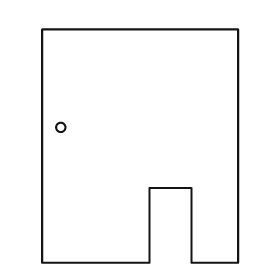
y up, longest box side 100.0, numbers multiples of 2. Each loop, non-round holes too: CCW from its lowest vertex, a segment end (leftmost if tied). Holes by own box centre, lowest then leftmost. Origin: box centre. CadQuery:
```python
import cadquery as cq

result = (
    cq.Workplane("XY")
    .moveTo(-42.0, -50.0)
    .lineTo(4.0, -50.0)
    .lineTo(4.0, -18.0)
    .lineTo(22.0, -18.0)
    .lineTo(22.0, -50.0)
    .lineTo(42.0, -50.0)
    .lineTo(42.0, 50.0)
    .lineTo(-42.0, 50.0)
    .close()
    .moveTo(-34.0, 8.0)
    .circle(2.0)
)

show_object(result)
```